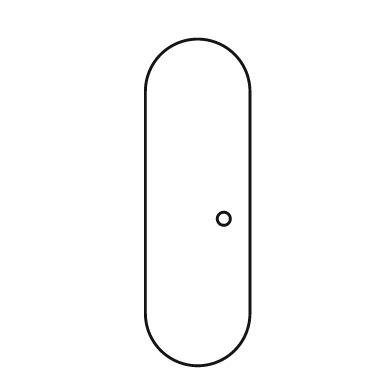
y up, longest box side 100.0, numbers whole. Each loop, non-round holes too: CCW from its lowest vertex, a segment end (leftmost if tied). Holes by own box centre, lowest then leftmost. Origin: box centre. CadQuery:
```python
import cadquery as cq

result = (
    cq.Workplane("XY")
    .moveTo(-16.0, -34.0)
    .threePointArc((0.0, -50.0), (16.0, -34.0))
    .lineTo(16.0, 34.0)
    .threePointArc((0.0, 50.0), (-16.0, 34.0))
    .close()
    .moveTo(8.0, -5.0)
    .circle(2.0)
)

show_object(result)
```